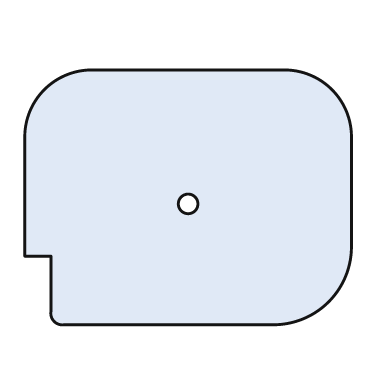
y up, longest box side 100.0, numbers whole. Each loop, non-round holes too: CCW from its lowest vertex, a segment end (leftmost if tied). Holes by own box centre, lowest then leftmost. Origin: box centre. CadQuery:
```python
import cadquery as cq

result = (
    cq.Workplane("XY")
    .moveTo(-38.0, -39.0)
    .lineTo(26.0, -39.0)
    .threePointArc((43.0, -32.0), (50.0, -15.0))
    .lineTo(50.0, 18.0)
    .threePointArc((44.0, 33.0), (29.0, 39.0))
    .lineTo(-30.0, 39.0)
    .threePointArc((-44.0, 33.0), (-50.0, 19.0))
    .lineTo(-50.0, -18.0)
    .lineTo(-42.0, -18.0)
    .lineTo(-42.0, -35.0)
    .threePointArc((-41.0, -38.0), (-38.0, -39.0))
    .close()
    .moveTo(0.0, -2.0)
    .circle(3.0)
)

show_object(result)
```